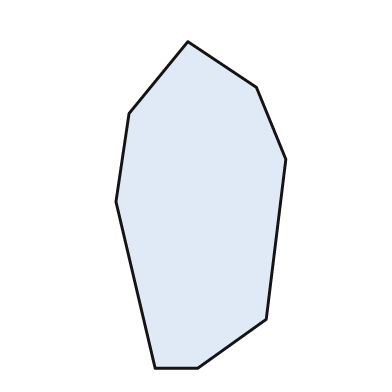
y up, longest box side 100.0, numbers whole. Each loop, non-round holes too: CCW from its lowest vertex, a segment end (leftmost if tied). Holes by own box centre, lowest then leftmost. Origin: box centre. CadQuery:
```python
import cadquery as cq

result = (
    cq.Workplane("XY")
    .moveTo(-14.0, -50.0)
    .lineTo(-1.0, -50.0)
    .lineTo(20.0, -35.0)
    .lineTo(26.0, 14.0)
    .lineTo(17.0, 36.0)
    .lineTo(-4.0, 50.0)
    .lineTo(-22.0, 28.0)
    .lineTo(-26.0, 1.0)
    .close()
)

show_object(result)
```